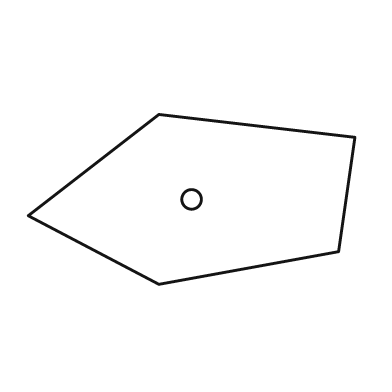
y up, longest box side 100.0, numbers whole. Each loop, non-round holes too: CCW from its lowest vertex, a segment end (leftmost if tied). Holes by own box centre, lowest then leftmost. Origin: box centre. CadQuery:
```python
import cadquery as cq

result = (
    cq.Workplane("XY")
    .moveTo(-10.0, -26.0)
    .lineTo(45.0, -16.0)
    .lineTo(50.0, 19.0)
    .lineTo(-10.0, 26.0)
    .lineTo(-50.0, -5.0)
    .close()
    .moveTo(0.0, 0.0)
    .circle(3.0)
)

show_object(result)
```